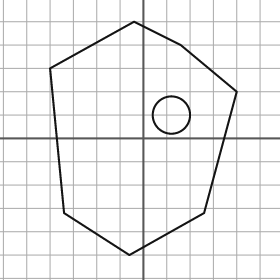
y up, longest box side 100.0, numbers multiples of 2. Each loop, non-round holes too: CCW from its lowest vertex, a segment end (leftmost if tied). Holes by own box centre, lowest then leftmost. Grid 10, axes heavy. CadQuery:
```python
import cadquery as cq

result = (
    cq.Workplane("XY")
    .moveTo(-6.0, -50.0)
    .lineTo(26.0, -32.0)
    .lineTo(40.0, 20.0)
    .lineTo(16.0, 40.0)
    .lineTo(-4.0, 50.0)
    .lineTo(-40.0, 30.0)
    .lineTo(-34.0, -32.0)
    .close()
    .moveTo(12.0, 10.0)
    .circle(8.0)
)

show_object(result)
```